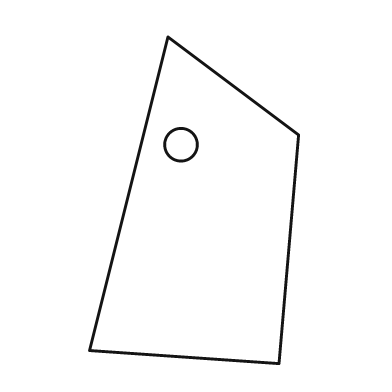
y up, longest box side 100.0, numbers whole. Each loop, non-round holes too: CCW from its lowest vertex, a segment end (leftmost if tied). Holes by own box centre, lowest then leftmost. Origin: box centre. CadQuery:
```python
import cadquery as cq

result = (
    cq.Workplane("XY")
    .moveTo(26.0, -50.0)
    .lineTo(32.0, 20.0)
    .lineTo(-8.0, 50.0)
    .lineTo(-32.0, -46.0)
    .close()
    .moveTo(-4.0, 17.0)
    .circle(5.0)
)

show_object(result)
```